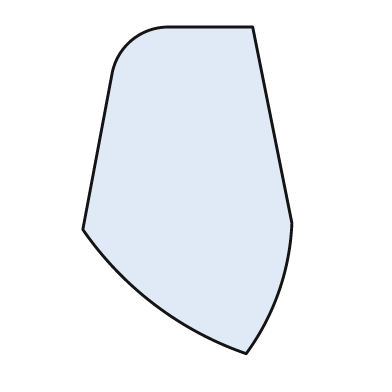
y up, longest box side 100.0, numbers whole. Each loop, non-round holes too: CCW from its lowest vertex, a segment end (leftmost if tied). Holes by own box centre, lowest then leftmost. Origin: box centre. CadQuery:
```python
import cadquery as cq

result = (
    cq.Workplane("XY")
    .moveTo(18.0, -50.0)
    .threePointArc((28.0, -31.0), (32.0, -10.0))
    .lineTo(20.0, 50.0)
    .lineTo(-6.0, 50.0)
    .threePointArc((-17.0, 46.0), (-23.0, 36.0))
    .lineTo(-32.0, -12.0)
    .threePointArc((-10.0, -35.0), (18.0, -50.0))
    .close()
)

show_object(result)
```